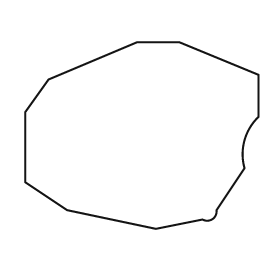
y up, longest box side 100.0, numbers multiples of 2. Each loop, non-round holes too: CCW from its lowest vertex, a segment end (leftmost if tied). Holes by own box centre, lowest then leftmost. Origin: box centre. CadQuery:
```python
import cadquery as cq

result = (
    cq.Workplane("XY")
    .moveTo(6.0, -40.0)
    .lineTo(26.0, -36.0)
    .threePointArc((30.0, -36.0), (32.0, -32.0))
    .lineTo(44.0, -14.0)
    .threePointArc((44.0, -2.0), (50.0, 8.0))
    .lineTo(50.0, 26.0)
    .lineTo(16.0, 40.0)
    .lineTo(-2.0, 40.0)
    .lineTo(-40.0, 24.0)
    .lineTo(-50.0, 10.0)
    .lineTo(-50.0, -20.0)
    .lineTo(-32.0, -32.0)
    .close()
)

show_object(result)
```